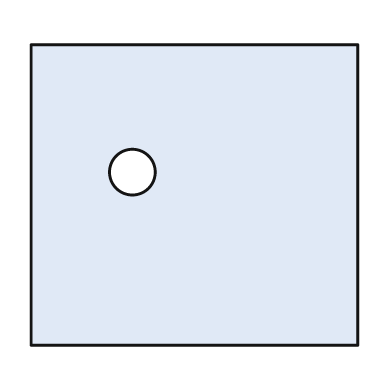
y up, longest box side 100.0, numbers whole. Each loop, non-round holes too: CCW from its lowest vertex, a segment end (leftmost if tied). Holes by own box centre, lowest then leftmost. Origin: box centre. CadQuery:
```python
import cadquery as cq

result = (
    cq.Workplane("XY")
    .moveTo(-50.0, -46.0)
    .lineTo(50.0, -46.0)
    .lineTo(50.0, 46.0)
    .lineTo(-50.0, 46.0)
    .close()
    .moveTo(-19.0, 7.0)
    .circle(7.0)
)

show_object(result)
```